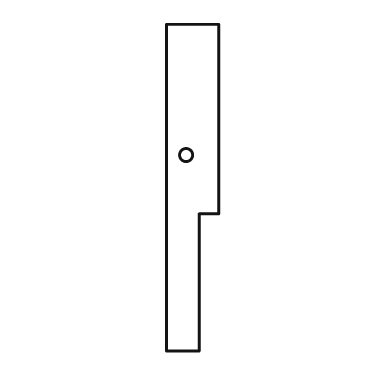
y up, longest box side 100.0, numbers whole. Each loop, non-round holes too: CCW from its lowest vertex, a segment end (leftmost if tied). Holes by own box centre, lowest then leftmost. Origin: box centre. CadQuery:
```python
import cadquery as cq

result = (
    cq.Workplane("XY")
    .moveTo(-8.0, -50.0)
    .lineTo(2.0, -50.0)
    .lineTo(2.0, -8.0)
    .lineTo(8.0, -8.0)
    .lineTo(8.0, 50.0)
    .lineTo(-8.0, 50.0)
    .close()
    .moveTo(-2.0, 10.0)
    .circle(2.0)
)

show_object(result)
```